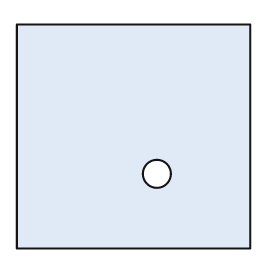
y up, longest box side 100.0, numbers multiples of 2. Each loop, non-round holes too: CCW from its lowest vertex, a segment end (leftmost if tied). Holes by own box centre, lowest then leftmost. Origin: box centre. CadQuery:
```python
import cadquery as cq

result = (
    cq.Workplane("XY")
    .moveTo(-50.0, -48.0)
    .lineTo(50.0, -48.0)
    .lineTo(50.0, 48.0)
    .lineTo(-50.0, 48.0)
    .close()
    .moveTo(10.0, -16.0)
    .circle(6.0)
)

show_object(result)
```